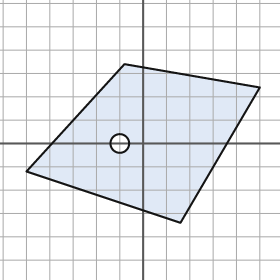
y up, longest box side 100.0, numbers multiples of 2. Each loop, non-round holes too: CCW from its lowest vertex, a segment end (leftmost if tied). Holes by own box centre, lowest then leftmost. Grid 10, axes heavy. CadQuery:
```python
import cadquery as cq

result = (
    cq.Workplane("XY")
    .moveTo(16.0, -34.0)
    .lineTo(50.0, 24.0)
    .lineTo(-8.0, 34.0)
    .lineTo(-50.0, -12.0)
    .close()
    .moveTo(-10.0, 0.0)
    .circle(4.0)
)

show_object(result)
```